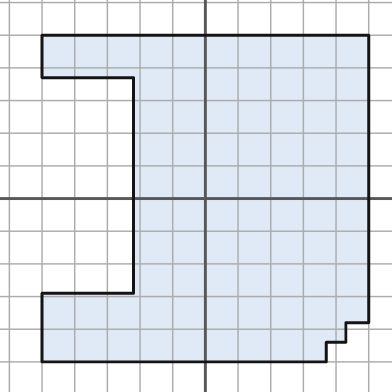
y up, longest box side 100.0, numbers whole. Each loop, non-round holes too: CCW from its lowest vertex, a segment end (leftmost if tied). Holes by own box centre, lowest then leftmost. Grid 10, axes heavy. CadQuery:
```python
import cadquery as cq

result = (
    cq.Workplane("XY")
    .moveTo(-50.0, -50.0)
    .lineTo(37.0, -50.0)
    .lineTo(37.0, -44.0)
    .lineTo(43.0, -44.0)
    .lineTo(43.0, -38.0)
    .lineTo(50.0, -38.0)
    .lineTo(50.0, 50.0)
    .lineTo(-50.0, 50.0)
    .lineTo(-50.0, 37.0)
    .lineTo(-22.0, 37.0)
    .lineTo(-22.0, -29.0)
    .lineTo(-50.0, -29.0)
    .close()
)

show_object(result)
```